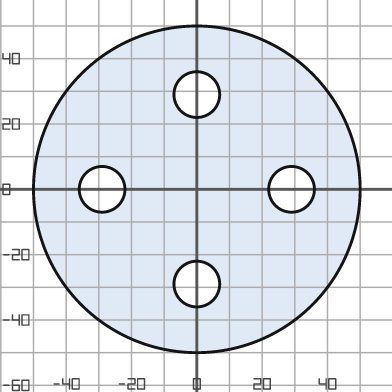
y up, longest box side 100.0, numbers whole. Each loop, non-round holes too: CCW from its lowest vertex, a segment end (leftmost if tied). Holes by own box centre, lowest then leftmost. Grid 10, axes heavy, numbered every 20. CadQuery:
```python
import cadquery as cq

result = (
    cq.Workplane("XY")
    .moveTo(0.0, 0.0)
    .circle(50.0)
    .moveTo(0.0, -29.0)
    .circle(7.0)
    .moveTo(-29.0, 0.0)
    .circle(7.0)
    .moveTo(29.0, 0.0)
    .circle(7.0)
    .moveTo(0.0, 29.0)
    .circle(7.0)
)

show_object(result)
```